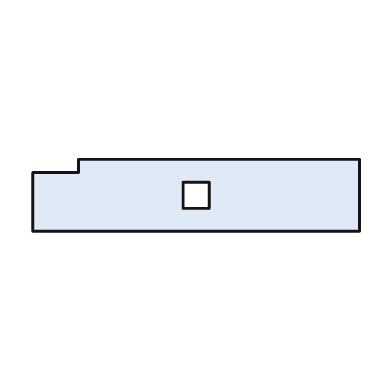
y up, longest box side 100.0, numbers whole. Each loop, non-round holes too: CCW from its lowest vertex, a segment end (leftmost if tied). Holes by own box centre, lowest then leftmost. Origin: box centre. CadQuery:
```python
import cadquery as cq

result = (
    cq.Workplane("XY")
    .moveTo(-50.0, -11.0)
    .lineTo(50.0, -11.0)
    .lineTo(50.0, 11.0)
    .lineTo(-36.0, 11.0)
    .lineTo(-36.0, 7.0)
    .lineTo(-50.0, 7.0)
    .close()
    .moveTo(-4.0, -4.0)
    .lineTo(4.0, -4.0)
    .lineTo(4.0, 4.0)
    .lineTo(-4.0, 4.0)
    .close()
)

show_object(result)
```